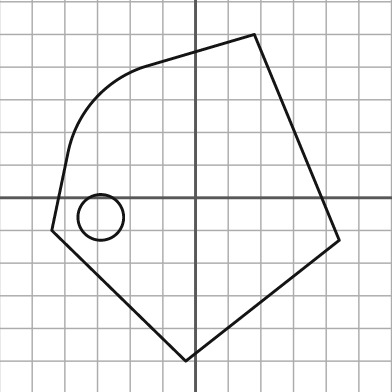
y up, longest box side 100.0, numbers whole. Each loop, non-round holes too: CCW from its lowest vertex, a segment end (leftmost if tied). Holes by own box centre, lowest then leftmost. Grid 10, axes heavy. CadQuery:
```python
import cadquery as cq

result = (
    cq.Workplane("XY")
    .moveTo(-3.0, -50.0)
    .lineTo(44.0, -13.0)
    .lineTo(18.0, 50.0)
    .lineTo(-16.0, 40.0)
    .threePointArc((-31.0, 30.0), (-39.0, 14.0))
    .lineTo(-44.0, -10.0)
    .close()
    .moveTo(-29.0, -6.0)
    .circle(7.0)
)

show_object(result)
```